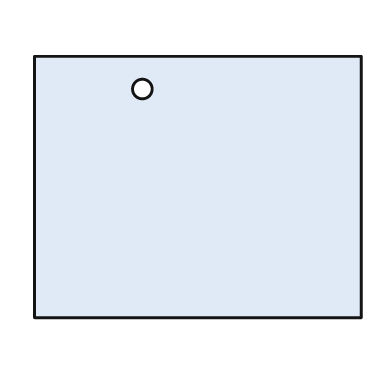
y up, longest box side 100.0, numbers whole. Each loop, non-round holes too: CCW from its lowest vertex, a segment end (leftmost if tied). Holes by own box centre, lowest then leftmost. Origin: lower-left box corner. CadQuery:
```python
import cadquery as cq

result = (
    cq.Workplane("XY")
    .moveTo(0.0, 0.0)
    .lineTo(100.0, 0.0)
    .lineTo(100.0, 80.0)
    .lineTo(0.0, 80.0)
    .close()
    .moveTo(33.0, 70.0)
    .circle(3.0)
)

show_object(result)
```